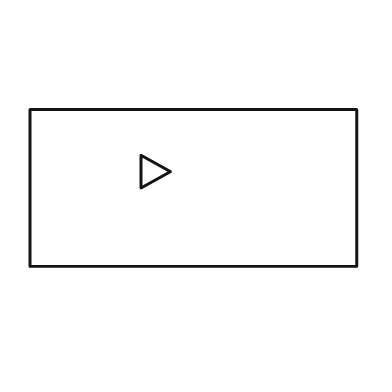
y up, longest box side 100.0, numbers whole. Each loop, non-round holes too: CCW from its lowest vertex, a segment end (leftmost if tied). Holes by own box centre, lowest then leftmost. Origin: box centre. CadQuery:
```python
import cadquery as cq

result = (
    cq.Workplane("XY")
    .moveTo(-50.0, -24.0)
    .lineTo(50.0, -24.0)
    .lineTo(50.0, 24.0)
    .lineTo(-50.0, 24.0)
    .close()
    .moveTo(-16.0, 0.0)
    .lineTo(-7.0, 5.0)
    .lineTo(-16.0, 10.0)
    .close()
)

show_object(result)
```